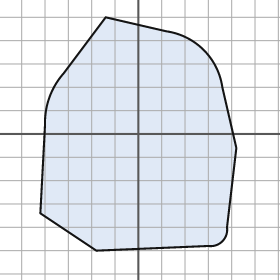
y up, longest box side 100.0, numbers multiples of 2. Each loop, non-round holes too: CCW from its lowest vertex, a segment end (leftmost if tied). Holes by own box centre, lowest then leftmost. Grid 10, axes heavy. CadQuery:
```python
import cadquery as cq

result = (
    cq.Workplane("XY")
    .moveTo(-18.0, -50.0)
    .lineTo(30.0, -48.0)
    .threePointArc((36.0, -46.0), (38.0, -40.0))
    .lineTo(42.0, -6.0)
    .lineTo(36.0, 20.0)
    .threePointArc((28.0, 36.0), (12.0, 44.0))
    .lineTo(-14.0, 50.0)
    .lineTo(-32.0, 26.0)
    .threePointArc((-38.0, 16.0), (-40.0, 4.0))
    .lineTo(-42.0, -34.0)
    .close()
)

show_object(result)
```